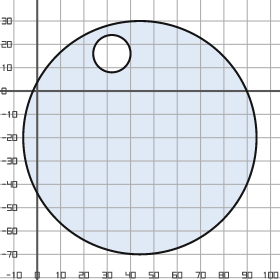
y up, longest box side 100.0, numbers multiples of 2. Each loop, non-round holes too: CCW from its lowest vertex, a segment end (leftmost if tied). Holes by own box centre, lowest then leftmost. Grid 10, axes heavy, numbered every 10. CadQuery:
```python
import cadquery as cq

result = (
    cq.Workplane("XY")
    .moveTo(44.0, -20.0)
    .circle(50.0)
    .moveTo(32.0, 16.0)
    .circle(8.0)
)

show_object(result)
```